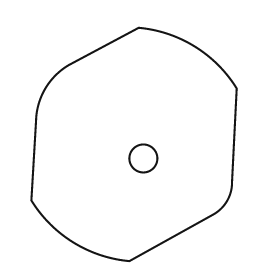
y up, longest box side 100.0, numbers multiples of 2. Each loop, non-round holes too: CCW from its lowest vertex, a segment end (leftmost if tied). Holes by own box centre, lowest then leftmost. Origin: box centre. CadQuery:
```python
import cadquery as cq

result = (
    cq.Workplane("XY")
    .moveTo(-2.0, -50.0)
    .lineTo(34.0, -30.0)
    .threePointArc((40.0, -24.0), (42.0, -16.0))
    .lineTo(44.0, 24.0)
    .threePointArc((26.0, 42.0), (2.0, 50.0))
    .lineTo(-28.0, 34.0)
    .threePointArc((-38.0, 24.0), (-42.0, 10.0))
    .lineTo(-44.0, -24.0)
    .threePointArc((-26.0, -42.0), (-2.0, -50.0))
    .close()
    .moveTo(4.0, -6.0)
    .circle(6.0)
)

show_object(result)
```